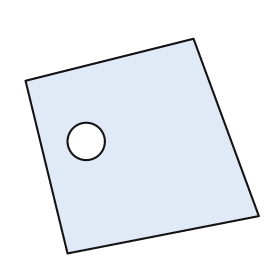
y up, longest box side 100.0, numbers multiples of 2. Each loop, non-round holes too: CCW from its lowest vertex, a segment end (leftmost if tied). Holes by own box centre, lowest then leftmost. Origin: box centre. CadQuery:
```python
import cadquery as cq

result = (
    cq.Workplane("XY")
    .moveTo(-32.0, -46.0)
    .lineTo(50.0, -30.0)
    .lineTo(22.0, 46.0)
    .lineTo(-50.0, 28.0)
    .close()
    .moveTo(-24.0, 2.0)
    .circle(8.0)
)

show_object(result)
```